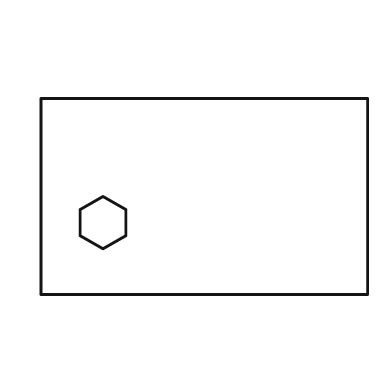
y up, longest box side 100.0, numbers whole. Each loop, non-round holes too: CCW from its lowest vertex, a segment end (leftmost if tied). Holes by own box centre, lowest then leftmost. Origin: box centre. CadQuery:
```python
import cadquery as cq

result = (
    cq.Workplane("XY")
    .moveTo(-50.0, -30.0)
    .lineTo(50.0, -30.0)
    .lineTo(50.0, 30.0)
    .lineTo(-50.0, 30.0)
    .close()
    .moveTo(-31.0, -16.0)
    .lineTo(-24.0, -12.0)
    .lineTo(-24.0, -4.0)
    .lineTo(-31.0, 0.0)
    .lineTo(-38.0, -4.0)
    .lineTo(-38.0, -12.0)
    .close()
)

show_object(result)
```